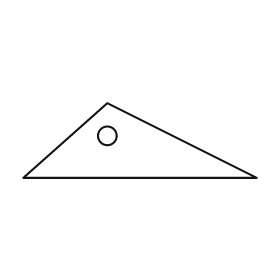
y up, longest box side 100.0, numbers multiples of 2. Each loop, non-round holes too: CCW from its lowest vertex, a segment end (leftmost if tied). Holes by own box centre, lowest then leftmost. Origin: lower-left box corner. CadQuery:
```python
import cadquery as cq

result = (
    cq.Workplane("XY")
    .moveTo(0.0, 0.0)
    .lineTo(100.0, 0.0)
    .lineTo(36.0, 32.0)
    .close()
    .moveTo(36.0, 18.0)
    .circle(4.0)
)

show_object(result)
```